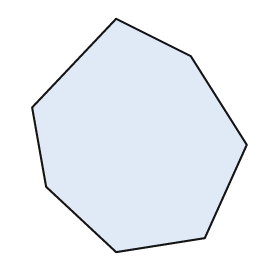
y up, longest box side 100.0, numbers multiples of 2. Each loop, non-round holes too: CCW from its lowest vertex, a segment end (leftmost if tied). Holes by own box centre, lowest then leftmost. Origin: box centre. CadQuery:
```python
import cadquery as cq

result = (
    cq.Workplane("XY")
    .moveTo(-10.0, -50.0)
    .lineTo(28.0, -44.0)
    .lineTo(46.0, -4.0)
    .lineTo(22.0, 34.0)
    .lineTo(-10.0, 50.0)
    .lineTo(-46.0, 12.0)
    .lineTo(-40.0, -22.0)
    .close()
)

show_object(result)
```